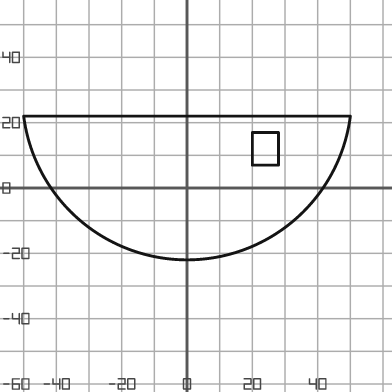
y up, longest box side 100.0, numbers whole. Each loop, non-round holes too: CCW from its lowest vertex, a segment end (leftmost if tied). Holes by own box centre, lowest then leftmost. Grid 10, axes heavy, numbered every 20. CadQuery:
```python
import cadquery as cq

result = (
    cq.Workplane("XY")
    .moveTo(-50.0, 22.0)
    .threePointArc((0.0, -22.0), (50.0, 22.0))
    .close()
    .moveTo(20.0, 7.0)
    .lineTo(28.0, 7.0)
    .lineTo(28.0, 17.0)
    .lineTo(20.0, 17.0)
    .close()
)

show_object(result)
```